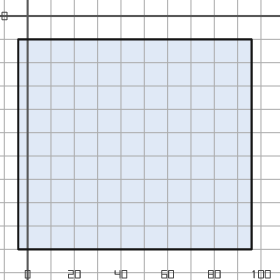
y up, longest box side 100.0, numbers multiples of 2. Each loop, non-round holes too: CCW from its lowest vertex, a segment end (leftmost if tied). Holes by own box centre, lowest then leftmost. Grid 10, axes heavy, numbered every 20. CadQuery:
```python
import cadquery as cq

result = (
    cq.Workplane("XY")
    .moveTo(-4.0, -100.0)
    .lineTo(96.0, -100.0)
    .lineTo(96.0, -10.0)
    .lineTo(-4.0, -10.0)
    .close()
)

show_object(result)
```